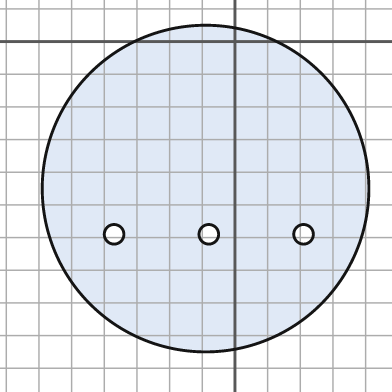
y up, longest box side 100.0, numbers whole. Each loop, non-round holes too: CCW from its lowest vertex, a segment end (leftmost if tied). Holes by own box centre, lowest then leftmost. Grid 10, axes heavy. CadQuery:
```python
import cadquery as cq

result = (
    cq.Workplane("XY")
    .moveTo(-9.0, -45.0)
    .circle(50.0)
    .moveTo(-37.0, -59.0)
    .circle(3.0)
    .moveTo(-8.0, -59.0)
    .circle(3.0)
    .moveTo(21.0, -59.0)
    .circle(3.0)
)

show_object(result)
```